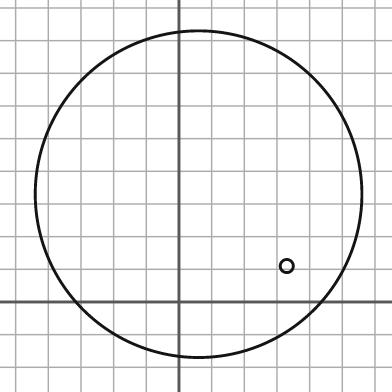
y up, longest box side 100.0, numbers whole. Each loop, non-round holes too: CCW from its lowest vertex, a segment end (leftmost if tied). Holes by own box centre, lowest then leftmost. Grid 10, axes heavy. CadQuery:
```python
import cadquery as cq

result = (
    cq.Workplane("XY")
    .moveTo(6.0, 33.0)
    .circle(50.0)
    .moveTo(33.0, 11.0)
    .circle(2.0)
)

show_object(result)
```